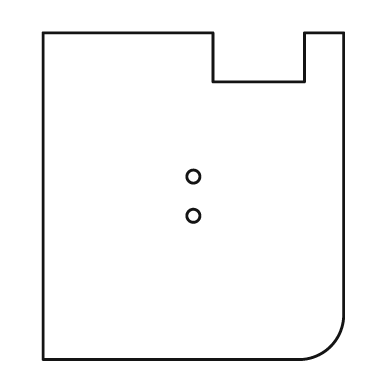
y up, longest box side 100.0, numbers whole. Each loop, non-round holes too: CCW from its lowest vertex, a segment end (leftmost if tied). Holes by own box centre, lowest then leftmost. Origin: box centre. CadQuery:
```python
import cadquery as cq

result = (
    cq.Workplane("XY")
    .moveTo(-46.0, -50.0)
    .lineTo(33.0, -50.0)
    .threePointArc((42.0, -46.0), (46.0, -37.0))
    .lineTo(46.0, 50.0)
    .lineTo(34.0, 50.0)
    .lineTo(34.0, 35.0)
    .lineTo(6.0, 35.0)
    .lineTo(6.0, 50.0)
    .lineTo(-46.0, 50.0)
    .close()
    .moveTo(0.0, -6.0)
    .circle(2.0)
    .moveTo(0.0, 6.0)
    .circle(2.0)
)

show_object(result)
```